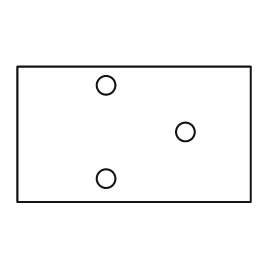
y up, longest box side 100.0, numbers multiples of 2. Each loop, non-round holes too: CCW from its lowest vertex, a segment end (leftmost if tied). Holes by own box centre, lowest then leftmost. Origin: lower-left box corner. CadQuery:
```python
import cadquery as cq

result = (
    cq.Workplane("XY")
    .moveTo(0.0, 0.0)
    .lineTo(100.0, 0.0)
    .lineTo(100.0, 58.0)
    .lineTo(0.0, 58.0)
    .close()
    .moveTo(38.0, 10.0)
    .circle(4.0)
    .moveTo(72.0, 30.0)
    .circle(4.0)
    .moveTo(38.0, 50.0)
    .circle(4.0)
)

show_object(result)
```